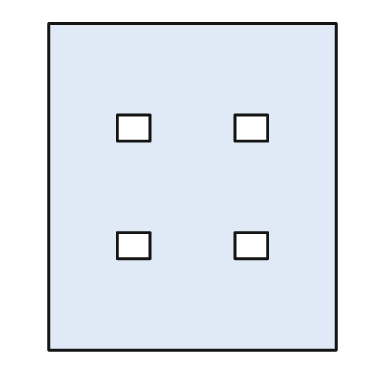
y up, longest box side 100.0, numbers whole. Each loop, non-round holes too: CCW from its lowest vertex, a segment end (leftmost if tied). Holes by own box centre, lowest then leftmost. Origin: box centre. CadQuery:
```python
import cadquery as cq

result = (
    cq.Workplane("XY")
    .moveTo(-44.0, -50.0)
    .lineTo(44.0, -50.0)
    .lineTo(44.0, 50.0)
    .lineTo(-44.0, 50.0)
    .close()
    .moveTo(-23.0, -22.0)
    .lineTo(-13.0, -22.0)
    .lineTo(-13.0, -14.0)
    .lineTo(-23.0, -14.0)
    .close()
    .moveTo(13.0, -22.0)
    .lineTo(23.0, -22.0)
    .lineTo(23.0, -14.0)
    .lineTo(13.0, -14.0)
    .close()
    .moveTo(-23.0, 14.0)
    .lineTo(-13.0, 14.0)
    .lineTo(-13.0, 22.0)
    .lineTo(-23.0, 22.0)
    .close()
    .moveTo(13.0, 14.0)
    .lineTo(23.0, 14.0)
    .lineTo(23.0, 22.0)
    .lineTo(13.0, 22.0)
    .close()
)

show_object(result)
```